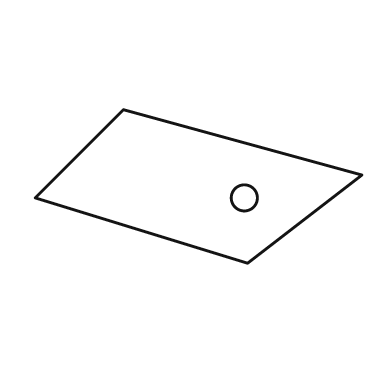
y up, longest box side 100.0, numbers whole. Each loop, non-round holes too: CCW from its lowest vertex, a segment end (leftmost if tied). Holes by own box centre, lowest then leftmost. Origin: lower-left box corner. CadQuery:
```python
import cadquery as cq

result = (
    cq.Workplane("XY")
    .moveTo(65.0, 0.0)
    .lineTo(100.0, 27.0)
    .lineTo(27.0, 47.0)
    .lineTo(0.0, 20.0)
    .close()
    .moveTo(64.0, 20.0)
    .circle(4.0)
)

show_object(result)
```